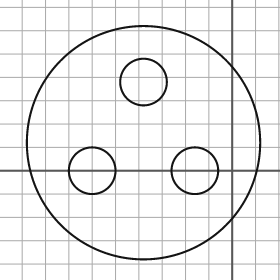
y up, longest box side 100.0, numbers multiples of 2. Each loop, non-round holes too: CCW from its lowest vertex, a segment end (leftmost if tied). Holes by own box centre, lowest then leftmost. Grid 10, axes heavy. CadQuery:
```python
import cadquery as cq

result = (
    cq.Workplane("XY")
    .moveTo(-38.0, 12.0)
    .circle(50.0)
    .moveTo(-60.0, 0.0)
    .circle(10.0)
    .moveTo(-16.0, 0.0)
    .circle(10.0)
    .moveTo(-38.0, 38.0)
    .circle(10.0)
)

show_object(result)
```